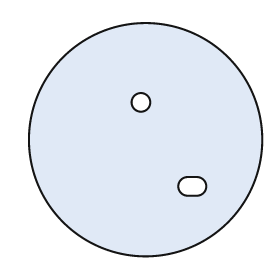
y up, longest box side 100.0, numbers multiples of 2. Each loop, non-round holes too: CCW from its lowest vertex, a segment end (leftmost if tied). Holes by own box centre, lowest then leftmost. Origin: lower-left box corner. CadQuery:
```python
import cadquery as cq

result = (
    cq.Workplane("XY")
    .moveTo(50.0, 50.0)
    .circle(50.0)
    .moveTo(68.0, 26.0)
    .lineTo(72.0, 26.0)
    .threePointArc((76.0, 30.0), (72.0, 34.0))
    .lineTo(68.0, 34.0)
    .threePointArc((64.0, 30.0), (68.0, 26.0))
    .close()
    .moveTo(48.0, 66.0)
    .circle(4.0)
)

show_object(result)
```